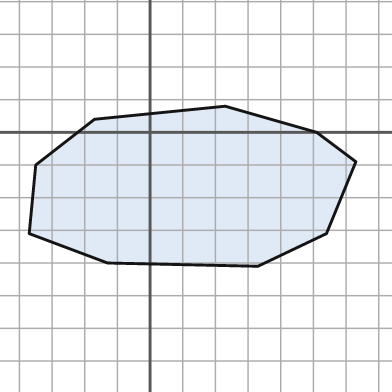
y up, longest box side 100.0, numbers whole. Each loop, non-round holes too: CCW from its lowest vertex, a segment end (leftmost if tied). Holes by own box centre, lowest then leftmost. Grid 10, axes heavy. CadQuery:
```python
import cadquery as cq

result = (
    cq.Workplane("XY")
    .moveTo(33.0, -41.0)
    .lineTo(54.0, -31.0)
    .lineTo(63.0, -9.0)
    .lineTo(51.0, 0.0)
    .lineTo(23.0, 8.0)
    .lineTo(-17.0, 4.0)
    .lineTo(-35.0, -10.0)
    .lineTo(-37.0, -31.0)
    .lineTo(-13.0, -40.0)
    .close()
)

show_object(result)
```